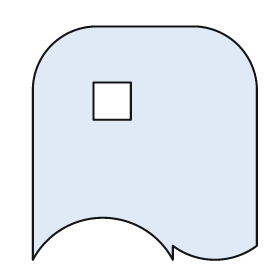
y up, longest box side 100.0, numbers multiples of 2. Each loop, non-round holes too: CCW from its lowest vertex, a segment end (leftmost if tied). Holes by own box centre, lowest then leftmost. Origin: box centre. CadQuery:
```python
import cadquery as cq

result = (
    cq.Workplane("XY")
    .moveTo(-48.0, -50.0)
    .threePointArc((-18.0, -32.0), (12.0, -50.0))
    .lineTo(12.0, -44.0)
    .threePointArc((30.0, -50.0), (48.0, -44.0))
    .lineTo(48.0, 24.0)
    .threePointArc((40.0, 42.0), (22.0, 50.0))
    .lineTo(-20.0, 50.0)
    .threePointArc((-40.0, 42.0), (-48.0, 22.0))
    .close()
    .moveTo(-22.0, 10.0)
    .lineTo(-6.0, 10.0)
    .lineTo(-6.0, 26.0)
    .lineTo(-22.0, 26.0)
    .close()
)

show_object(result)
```